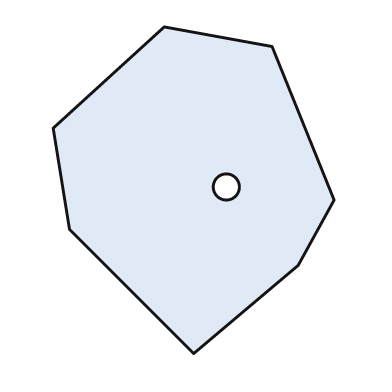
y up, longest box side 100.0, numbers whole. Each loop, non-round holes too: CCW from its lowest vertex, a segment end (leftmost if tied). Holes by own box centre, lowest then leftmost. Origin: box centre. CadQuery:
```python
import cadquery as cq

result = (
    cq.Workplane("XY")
    .moveTo(0.0, -50.0)
    .lineTo(32.0, -23.0)
    .lineTo(43.0, -3.0)
    .lineTo(24.0, 44.0)
    .lineTo(-9.0, 50.0)
    .lineTo(-43.0, 19.0)
    .lineTo(-38.0, -12.0)
    .close()
    .moveTo(10.0, 1.0)
    .circle(4.0)
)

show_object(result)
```